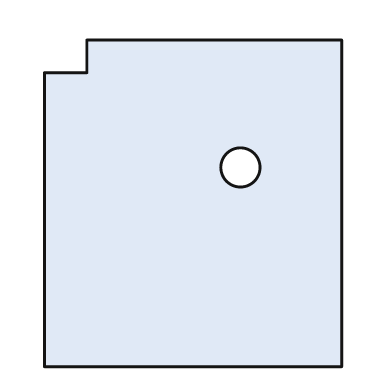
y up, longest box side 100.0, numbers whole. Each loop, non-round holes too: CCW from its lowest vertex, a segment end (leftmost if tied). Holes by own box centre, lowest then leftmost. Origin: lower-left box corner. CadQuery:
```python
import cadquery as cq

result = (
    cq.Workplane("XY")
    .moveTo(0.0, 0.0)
    .lineTo(91.0, 0.0)
    .lineTo(91.0, 100.0)
    .lineTo(13.0, 100.0)
    .lineTo(13.0, 90.0)
    .lineTo(0.0, 90.0)
    .close()
    .moveTo(60.0, 61.0)
    .circle(6.0)
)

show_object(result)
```